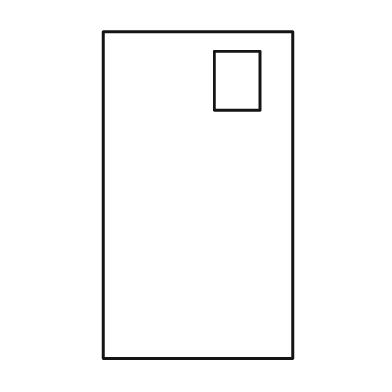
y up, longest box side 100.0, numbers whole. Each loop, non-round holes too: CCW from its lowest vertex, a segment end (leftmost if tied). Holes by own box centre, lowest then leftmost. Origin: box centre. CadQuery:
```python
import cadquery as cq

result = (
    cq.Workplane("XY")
    .moveTo(-29.0, -50.0)
    .lineTo(29.0, -50.0)
    .lineTo(29.0, 50.0)
    .lineTo(-29.0, 50.0)
    .close()
    .moveTo(5.0, 26.0)
    .lineTo(19.0, 26.0)
    .lineTo(19.0, 44.0)
    .lineTo(5.0, 44.0)
    .close()
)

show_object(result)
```